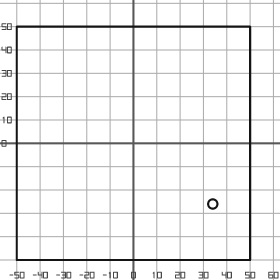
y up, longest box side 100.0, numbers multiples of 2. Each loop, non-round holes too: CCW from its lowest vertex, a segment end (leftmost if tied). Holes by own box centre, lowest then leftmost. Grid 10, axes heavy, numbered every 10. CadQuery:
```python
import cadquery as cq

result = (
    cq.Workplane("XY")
    .moveTo(-50.0, -50.0)
    .lineTo(50.0, -50.0)
    .lineTo(50.0, 50.0)
    .lineTo(-50.0, 50.0)
    .close()
    .moveTo(34.0, -26.0)
    .circle(2.0)
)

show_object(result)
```